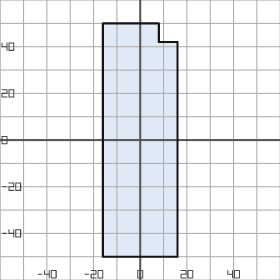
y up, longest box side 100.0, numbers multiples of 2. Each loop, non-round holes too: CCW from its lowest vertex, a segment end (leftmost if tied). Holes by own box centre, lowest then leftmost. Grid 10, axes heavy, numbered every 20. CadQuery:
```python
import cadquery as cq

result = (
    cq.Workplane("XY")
    .moveTo(-16.0, -50.0)
    .lineTo(16.0, -50.0)
    .lineTo(16.0, 42.0)
    .lineTo(8.0, 42.0)
    .lineTo(8.0, 50.0)
    .lineTo(-16.0, 50.0)
    .close()
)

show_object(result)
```